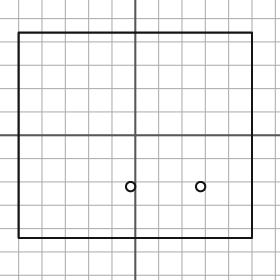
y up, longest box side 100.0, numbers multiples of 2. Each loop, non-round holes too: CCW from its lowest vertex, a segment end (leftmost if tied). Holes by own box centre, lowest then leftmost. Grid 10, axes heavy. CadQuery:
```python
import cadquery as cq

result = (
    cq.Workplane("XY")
    .moveTo(-50.0, -44.0)
    .lineTo(50.0, -44.0)
    .lineTo(50.0, 44.0)
    .lineTo(-50.0, 44.0)
    .close()
    .moveTo(-2.0, -22.0)
    .circle(2.0)
    .moveTo(28.0, -22.0)
    .circle(2.0)
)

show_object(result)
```